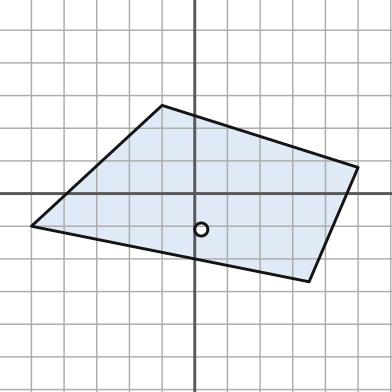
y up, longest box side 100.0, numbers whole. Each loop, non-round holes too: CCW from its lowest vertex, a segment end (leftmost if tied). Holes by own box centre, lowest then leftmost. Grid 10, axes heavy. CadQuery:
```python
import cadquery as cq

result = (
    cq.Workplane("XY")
    .moveTo(35.0, -27.0)
    .lineTo(50.0, 8.0)
    .lineTo(-10.0, 27.0)
    .lineTo(-50.0, -10.0)
    .close()
    .moveTo(2.0, -11.0)
    .circle(2.0)
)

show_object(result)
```